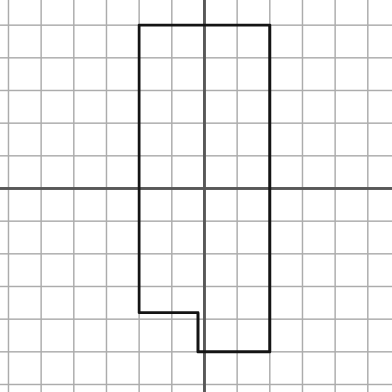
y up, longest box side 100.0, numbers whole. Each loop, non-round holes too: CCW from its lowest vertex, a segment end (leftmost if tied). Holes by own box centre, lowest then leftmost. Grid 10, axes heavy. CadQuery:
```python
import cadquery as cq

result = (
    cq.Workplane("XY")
    .moveTo(-2.0, -50.0)
    .lineTo(20.0, -50.0)
    .lineTo(20.0, 50.0)
    .lineTo(-20.0, 50.0)
    .lineTo(-20.0, -38.0)
    .lineTo(-2.0, -38.0)
    .close()
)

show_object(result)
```